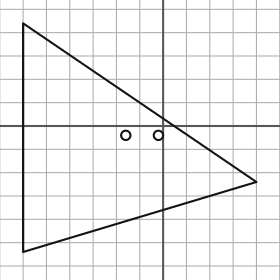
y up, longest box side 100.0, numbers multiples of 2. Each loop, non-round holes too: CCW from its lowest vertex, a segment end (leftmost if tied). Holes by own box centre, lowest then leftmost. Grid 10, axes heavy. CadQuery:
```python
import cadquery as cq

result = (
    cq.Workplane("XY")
    .moveTo(-60.0, -54.0)
    .lineTo(40.0, -24.0)
    .lineTo(-60.0, 44.0)
    .close()
    .moveTo(-16.0, -4.0)
    .circle(2.0)
    .moveTo(-2.0, -4.0)
    .circle(2.0)
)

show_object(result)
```